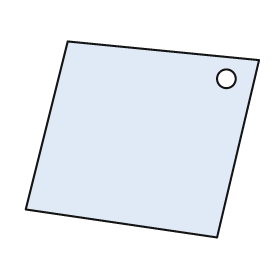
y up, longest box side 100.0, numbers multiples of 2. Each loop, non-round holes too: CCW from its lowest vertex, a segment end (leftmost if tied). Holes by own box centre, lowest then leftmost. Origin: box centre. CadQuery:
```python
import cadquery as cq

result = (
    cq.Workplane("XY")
    .moveTo(32.0, -42.0)
    .lineTo(50.0, 34.0)
    .lineTo(-32.0, 42.0)
    .lineTo(-50.0, -30.0)
    .close()
    .moveTo(36.0, 26.0)
    .circle(4.0)
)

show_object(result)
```